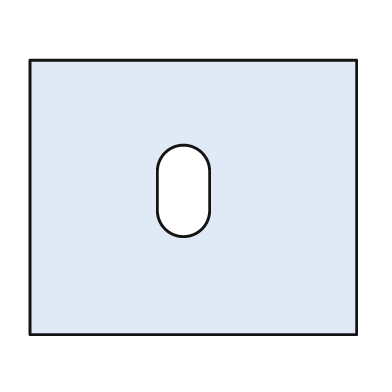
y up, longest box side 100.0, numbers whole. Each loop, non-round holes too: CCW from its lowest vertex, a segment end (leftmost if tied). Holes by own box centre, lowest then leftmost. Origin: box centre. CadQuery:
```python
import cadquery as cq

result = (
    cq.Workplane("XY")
    .moveTo(-50.0, -42.0)
    .lineTo(50.0, -42.0)
    .lineTo(50.0, 42.0)
    .lineTo(-50.0, 42.0)
    .close()
    .moveTo(-11.0, -4.0)
    .threePointArc((-3.0, -12.0), (5.0, -4.0))
    .lineTo(5.0, 8.0)
    .threePointArc((-3.0, 16.0), (-11.0, 8.0))
    .close()
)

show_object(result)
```